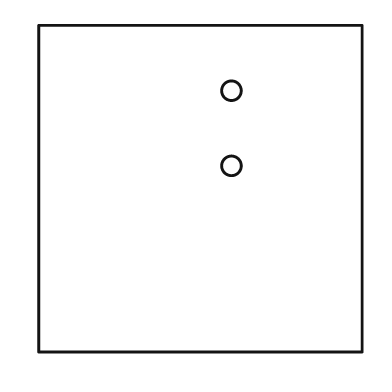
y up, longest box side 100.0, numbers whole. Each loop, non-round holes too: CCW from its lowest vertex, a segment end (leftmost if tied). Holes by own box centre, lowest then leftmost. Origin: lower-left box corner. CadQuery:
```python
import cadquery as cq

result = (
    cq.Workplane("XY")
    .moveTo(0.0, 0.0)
    .lineTo(99.0, 0.0)
    .lineTo(99.0, 100.0)
    .lineTo(0.0, 100.0)
    .close()
    .moveTo(59.0, 57.0)
    .circle(3.0)
    .moveTo(59.0, 80.0)
    .circle(3.0)
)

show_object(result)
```